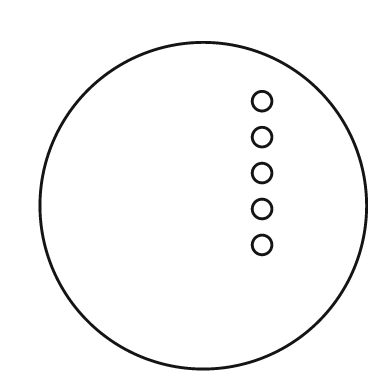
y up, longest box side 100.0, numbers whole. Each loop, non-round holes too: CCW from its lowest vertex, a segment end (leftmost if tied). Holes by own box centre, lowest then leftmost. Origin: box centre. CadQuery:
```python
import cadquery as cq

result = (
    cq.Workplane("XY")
    .moveTo(0.0, 0.0)
    .circle(50.0)
    .moveTo(18.0, -12.0)
    .circle(3.0)
    .moveTo(18.0, -1.0)
    .circle(3.0)
    .moveTo(18.0, 10.0)
    .circle(3.0)
    .moveTo(18.0, 21.0)
    .circle(3.0)
    .moveTo(18.0, 32.0)
    .circle(3.0)
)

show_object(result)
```